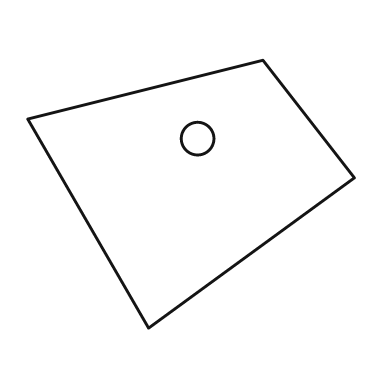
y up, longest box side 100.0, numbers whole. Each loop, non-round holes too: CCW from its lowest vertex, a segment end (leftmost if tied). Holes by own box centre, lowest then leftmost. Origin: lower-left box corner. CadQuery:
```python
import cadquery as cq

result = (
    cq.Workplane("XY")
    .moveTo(37.0, 0.0)
    .lineTo(100.0, 46.0)
    .lineTo(72.0, 82.0)
    .lineTo(0.0, 64.0)
    .close()
    .moveTo(52.0, 58.0)
    .circle(5.0)
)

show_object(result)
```